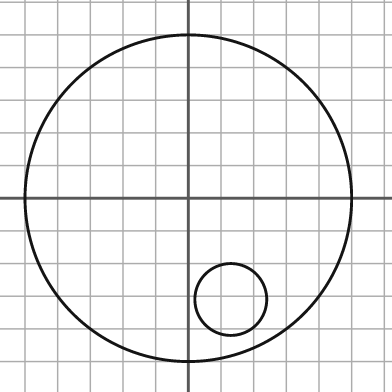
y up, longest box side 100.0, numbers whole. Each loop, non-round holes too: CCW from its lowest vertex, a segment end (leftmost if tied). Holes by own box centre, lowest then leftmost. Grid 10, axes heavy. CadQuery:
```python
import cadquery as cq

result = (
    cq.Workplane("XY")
    .moveTo(0.0, 0.0)
    .circle(50.0)
    .moveTo(13.0, -31.0)
    .circle(11.0)
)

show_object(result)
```